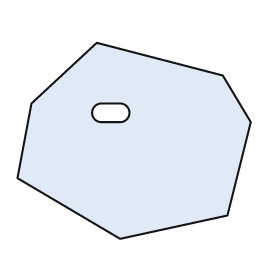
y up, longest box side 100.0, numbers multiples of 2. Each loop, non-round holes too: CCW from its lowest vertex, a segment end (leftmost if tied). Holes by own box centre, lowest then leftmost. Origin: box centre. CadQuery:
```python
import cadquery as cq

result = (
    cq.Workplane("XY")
    .moveTo(-6.0, -42.0)
    .lineTo(40.0, -32.0)
    .lineTo(50.0, 8.0)
    .lineTo(38.0, 28.0)
    .lineTo(-16.0, 42.0)
    .lineTo(-44.0, 16.0)
    .lineTo(-50.0, -16.0)
    .close()
    .moveTo(-14.0, 8.0)
    .lineTo(-6.0, 8.0)
    .threePointArc((-2.0, 12.0), (-6.0, 16.0))
    .lineTo(-14.0, 16.0)
    .threePointArc((-18.0, 12.0), (-14.0, 8.0))
    .close()
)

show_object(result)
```